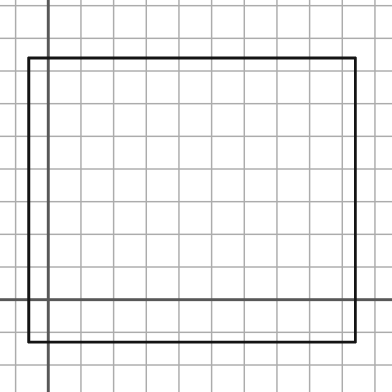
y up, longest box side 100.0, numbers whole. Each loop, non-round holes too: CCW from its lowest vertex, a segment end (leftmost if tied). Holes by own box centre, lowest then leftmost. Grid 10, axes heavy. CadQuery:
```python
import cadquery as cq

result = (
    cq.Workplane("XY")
    .moveTo(-6.0, -13.0)
    .lineTo(94.0, -13.0)
    .lineTo(94.0, 74.0)
    .lineTo(-6.0, 74.0)
    .close()
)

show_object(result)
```